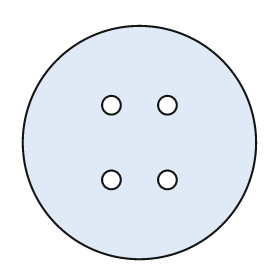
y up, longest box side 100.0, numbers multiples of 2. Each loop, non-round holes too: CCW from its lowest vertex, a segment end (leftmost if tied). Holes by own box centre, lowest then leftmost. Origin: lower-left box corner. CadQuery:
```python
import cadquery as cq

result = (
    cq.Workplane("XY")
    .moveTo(50.0, 50.0)
    .circle(50.0)
    .moveTo(38.0, 34.0)
    .circle(4.0)
    .moveTo(62.0, 34.0)
    .circle(4.0)
    .moveTo(38.0, 66.0)
    .circle(4.0)
    .moveTo(62.0, 66.0)
    .circle(4.0)
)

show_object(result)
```